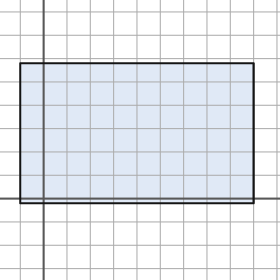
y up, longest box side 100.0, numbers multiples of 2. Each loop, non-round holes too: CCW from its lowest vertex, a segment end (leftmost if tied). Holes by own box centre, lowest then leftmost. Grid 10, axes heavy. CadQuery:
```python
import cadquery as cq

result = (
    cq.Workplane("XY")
    .moveTo(-10.0, -2.0)
    .lineTo(90.0, -2.0)
    .lineTo(90.0, 58.0)
    .lineTo(-10.0, 58.0)
    .close()
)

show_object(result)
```